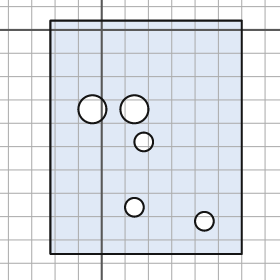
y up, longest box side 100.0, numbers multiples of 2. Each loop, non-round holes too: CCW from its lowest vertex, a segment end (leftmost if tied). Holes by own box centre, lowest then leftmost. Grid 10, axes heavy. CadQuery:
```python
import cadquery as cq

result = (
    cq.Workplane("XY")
    .moveTo(-22.0, -96.0)
    .lineTo(60.0, -96.0)
    .lineTo(60.0, 4.0)
    .lineTo(-22.0, 4.0)
    .close()
    .moveTo(44.0, -82.0)
    .circle(4.0)
    .moveTo(14.0, -76.0)
    .circle(4.0)
    .moveTo(18.0, -48.0)
    .circle(4.0)
    .moveTo(-4.0, -34.0)
    .circle(6.0)
    .moveTo(14.0, -34.0)
    .circle(6.0)
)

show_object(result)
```